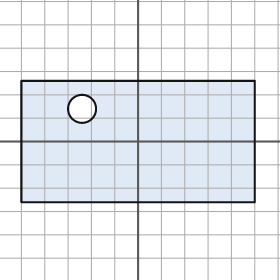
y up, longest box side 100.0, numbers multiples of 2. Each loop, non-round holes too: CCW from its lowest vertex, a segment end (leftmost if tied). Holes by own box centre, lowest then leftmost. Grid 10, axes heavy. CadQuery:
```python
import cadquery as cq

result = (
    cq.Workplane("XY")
    .moveTo(-50.0, -26.0)
    .lineTo(50.0, -26.0)
    .lineTo(50.0, 26.0)
    .lineTo(-50.0, 26.0)
    .close()
    .moveTo(-24.0, 14.0)
    .circle(6.0)
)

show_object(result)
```